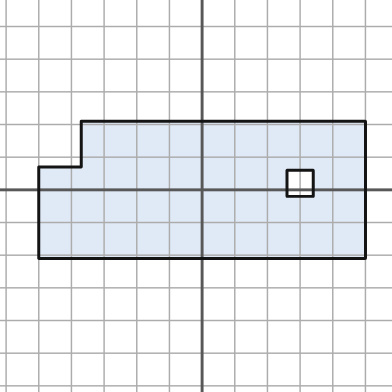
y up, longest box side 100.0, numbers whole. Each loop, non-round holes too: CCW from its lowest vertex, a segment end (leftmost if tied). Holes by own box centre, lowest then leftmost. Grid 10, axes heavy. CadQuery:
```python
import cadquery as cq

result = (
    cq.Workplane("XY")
    .moveTo(-50.0, -21.0)
    .lineTo(50.0, -21.0)
    .lineTo(50.0, 21.0)
    .lineTo(-37.0, 21.0)
    .lineTo(-37.0, 7.0)
    .lineTo(-50.0, 7.0)
    .close()
    .moveTo(26.0, -2.0)
    .lineTo(34.0, -2.0)
    .lineTo(34.0, 6.0)
    .lineTo(26.0, 6.0)
    .close()
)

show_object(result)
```